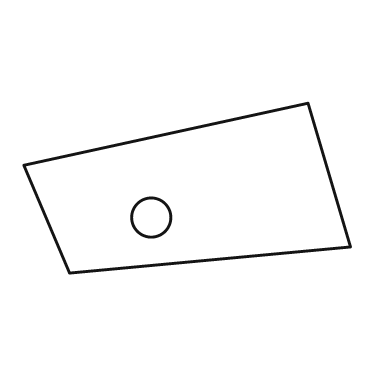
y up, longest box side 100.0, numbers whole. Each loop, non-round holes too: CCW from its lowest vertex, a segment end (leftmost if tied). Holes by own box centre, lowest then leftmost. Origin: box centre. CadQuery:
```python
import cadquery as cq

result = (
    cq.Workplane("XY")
    .moveTo(-36.0, -26.0)
    .lineTo(50.0, -18.0)
    .lineTo(37.0, 26.0)
    .lineTo(-50.0, 7.0)
    .close()
    .moveTo(-11.0, -9.0)
    .circle(6.0)
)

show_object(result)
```